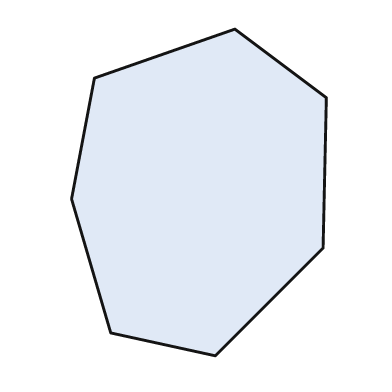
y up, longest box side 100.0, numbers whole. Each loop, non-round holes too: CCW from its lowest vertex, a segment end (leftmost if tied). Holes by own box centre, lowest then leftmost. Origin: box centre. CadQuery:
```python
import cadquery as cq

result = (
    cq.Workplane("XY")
    .moveTo(5.0, -50.0)
    .lineTo(38.0, -17.0)
    .lineTo(39.0, 29.0)
    .lineTo(11.0, 50.0)
    .lineTo(-32.0, 35.0)
    .lineTo(-39.0, -2.0)
    .lineTo(-27.0, -43.0)
    .close()
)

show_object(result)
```